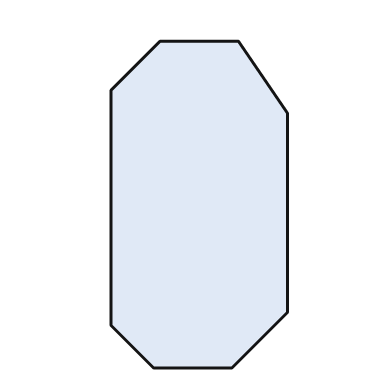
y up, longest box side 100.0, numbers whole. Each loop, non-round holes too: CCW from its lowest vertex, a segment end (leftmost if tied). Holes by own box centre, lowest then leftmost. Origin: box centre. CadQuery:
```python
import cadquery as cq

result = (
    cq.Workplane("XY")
    .moveTo(-14.0, -50.0)
    .lineTo(10.0, -50.0)
    .lineTo(27.0, -33.0)
    .lineTo(27.0, 28.0)
    .lineTo(12.0, 50.0)
    .lineTo(-12.0, 50.0)
    .lineTo(-27.0, 35.0)
    .lineTo(-27.0, -37.0)
    .close()
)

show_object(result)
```